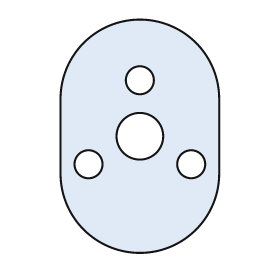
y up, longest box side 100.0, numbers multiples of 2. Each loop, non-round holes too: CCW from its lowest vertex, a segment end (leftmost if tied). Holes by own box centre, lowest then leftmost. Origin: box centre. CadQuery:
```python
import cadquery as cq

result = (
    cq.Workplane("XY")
    .moveTo(-34.0, -16.0)
    .threePointArc((0.0, -50.0), (34.0, -16.0))
    .lineTo(34.0, 16.0)
    .threePointArc((0.0, 50.0), (-34.0, 16.0))
    .close()
    .moveTo(-22.0, -12.0)
    .circle(6.0)
    .moveTo(22.0, -12.0)
    .circle(6.0)
    .moveTo(0.0, 0.0)
    .circle(10.0)
    .moveTo(0.0, 24.0)
    .circle(6.0)
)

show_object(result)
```